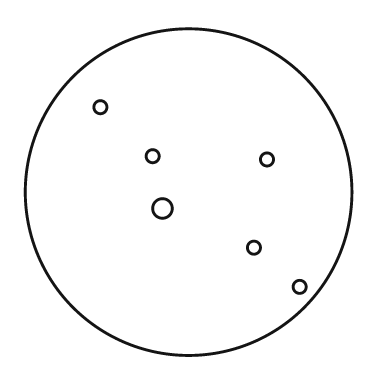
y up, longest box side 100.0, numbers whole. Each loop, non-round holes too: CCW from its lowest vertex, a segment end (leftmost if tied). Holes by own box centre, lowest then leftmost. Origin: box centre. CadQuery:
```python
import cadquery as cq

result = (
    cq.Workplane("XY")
    .moveTo(0.0, 0.0)
    .circle(50.0)
    .moveTo(34.0, -29.0)
    .circle(2.0)
    .moveTo(20.0, -17.0)
    .circle(2.0)
    .moveTo(-8.0, -5.0)
    .circle(3.0)
    .moveTo(24.0, 10.0)
    .circle(2.0)
    .moveTo(-11.0, 11.0)
    .circle(2.0)
    .moveTo(-27.0, 26.0)
    .circle(2.0)
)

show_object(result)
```